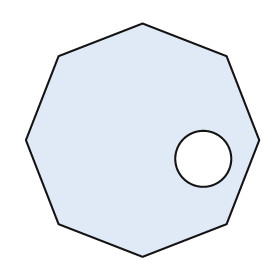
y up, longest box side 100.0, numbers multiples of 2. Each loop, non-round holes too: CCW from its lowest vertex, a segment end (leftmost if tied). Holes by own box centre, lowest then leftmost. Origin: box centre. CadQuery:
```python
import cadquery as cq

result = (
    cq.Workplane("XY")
    .moveTo(0.0, -50.0)
    .lineTo(36.0, -36.0)
    .lineTo(50.0, 0.0)
    .lineTo(36.0, 36.0)
    .lineTo(0.0, 50.0)
    .lineTo(-36.0, 36.0)
    .lineTo(-50.0, 0.0)
    .lineTo(-36.0, -36.0)
    .close()
    .moveTo(26.0, -8.0)
    .circle(12.0)
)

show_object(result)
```